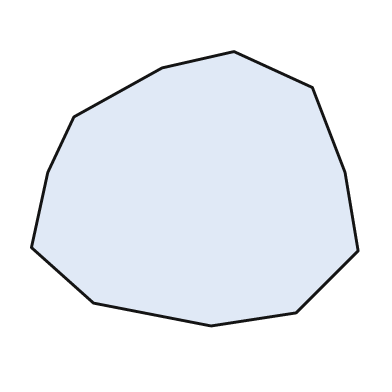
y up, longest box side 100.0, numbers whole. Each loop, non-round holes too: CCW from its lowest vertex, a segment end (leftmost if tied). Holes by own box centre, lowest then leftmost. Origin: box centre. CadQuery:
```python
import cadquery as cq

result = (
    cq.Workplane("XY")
    .moveTo(5.0, -42.0)
    .lineTo(31.0, -38.0)
    .lineTo(50.0, -19.0)
    .lineTo(46.0, 5.0)
    .lineTo(36.0, 31.0)
    .lineTo(12.0, 42.0)
    .lineTo(-10.0, 37.0)
    .lineTo(-37.0, 22.0)
    .lineTo(-45.0, 5.0)
    .lineTo(-50.0, -18.0)
    .lineTo(-31.0, -35.0)
    .close()
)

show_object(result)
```